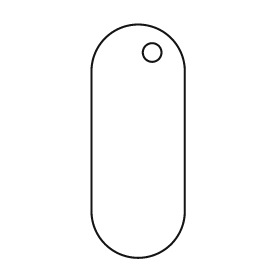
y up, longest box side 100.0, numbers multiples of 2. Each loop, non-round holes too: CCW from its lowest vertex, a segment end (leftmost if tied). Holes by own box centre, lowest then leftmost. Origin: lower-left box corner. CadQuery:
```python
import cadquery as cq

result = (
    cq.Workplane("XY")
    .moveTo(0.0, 20.0)
    .threePointArc((20.0, 0.0), (40.0, 20.0))
    .lineTo(40.0, 80.0)
    .threePointArc((20.0, 100.0), (0.0, 80.0))
    .close()
    .moveTo(26.0, 88.0)
    .circle(4.0)
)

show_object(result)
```